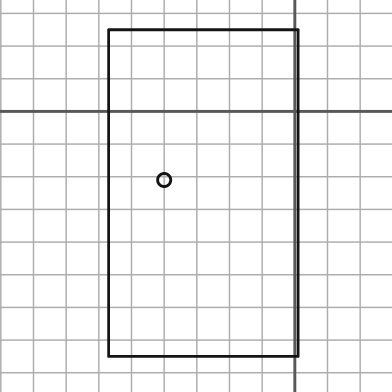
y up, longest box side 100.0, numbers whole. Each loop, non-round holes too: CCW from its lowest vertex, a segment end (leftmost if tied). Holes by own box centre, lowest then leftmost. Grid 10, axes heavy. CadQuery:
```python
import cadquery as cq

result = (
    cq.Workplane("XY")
    .moveTo(-57.0, -75.0)
    .lineTo(1.0, -75.0)
    .lineTo(1.0, 25.0)
    .lineTo(-57.0, 25.0)
    .close()
    .moveTo(-40.0, -21.0)
    .circle(2.0)
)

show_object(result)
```